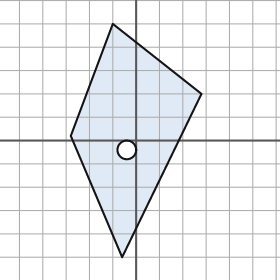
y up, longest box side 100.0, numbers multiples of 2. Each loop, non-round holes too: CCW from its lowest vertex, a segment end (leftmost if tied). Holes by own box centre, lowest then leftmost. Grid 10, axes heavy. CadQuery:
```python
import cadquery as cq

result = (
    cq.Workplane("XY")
    .moveTo(-6.0, -50.0)
    .lineTo(28.0, 20.0)
    .lineTo(-10.0, 50.0)
    .lineTo(-28.0, 2.0)
    .close()
    .moveTo(-4.0, -4.0)
    .circle(4.0)
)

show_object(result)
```